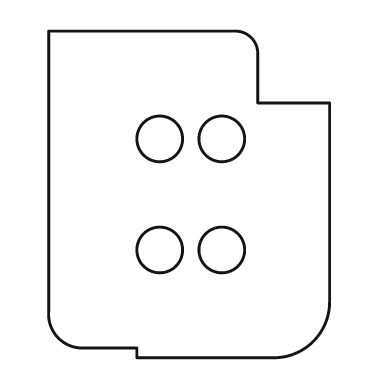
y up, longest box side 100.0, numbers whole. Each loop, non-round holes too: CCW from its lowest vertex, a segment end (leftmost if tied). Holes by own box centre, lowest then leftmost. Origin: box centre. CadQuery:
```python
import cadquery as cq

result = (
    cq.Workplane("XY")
    .moveTo(-16.0, -50.0)
    .lineTo(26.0, -50.0)
    .threePointArc((38.0, -45.0), (43.0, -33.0))
    .lineTo(43.0, 28.0)
    .lineTo(21.0, 28.0)
    .lineTo(21.0, 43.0)
    .threePointArc((19.0, 48.0), (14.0, 50.0))
    .lineTo(-43.0, 50.0)
    .lineTo(-43.0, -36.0)
    .threePointArc((-40.0, -44.0), (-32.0, -47.0))
    .lineTo(-16.0, -47.0)
    .close()
    .moveTo(-9.0, -17.0)
    .circle(7.0)
    .moveTo(10.0, -17.0)
    .circle(7.0)
    .moveTo(-9.0, 17.0)
    .circle(7.0)
    .moveTo(10.0, 17.0)
    .circle(7.0)
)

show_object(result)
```